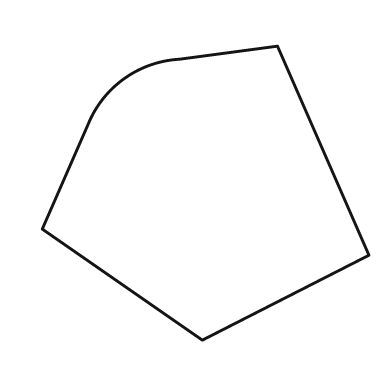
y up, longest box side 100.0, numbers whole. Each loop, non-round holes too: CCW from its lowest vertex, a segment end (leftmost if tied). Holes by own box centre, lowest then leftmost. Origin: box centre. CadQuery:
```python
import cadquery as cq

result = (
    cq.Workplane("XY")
    .moveTo(-1.0, -45.0)
    .lineTo(50.0, -19.0)
    .lineTo(22.0, 45.0)
    .lineTo(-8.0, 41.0)
    .threePointArc((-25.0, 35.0), (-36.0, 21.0))
    .lineTo(-50.0, -11.0)
    .close()
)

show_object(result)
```